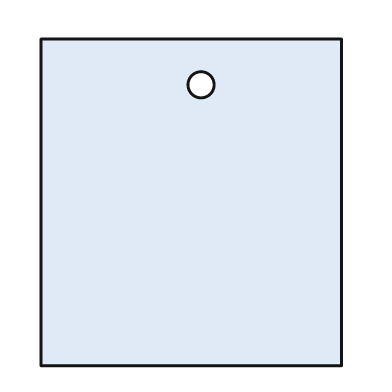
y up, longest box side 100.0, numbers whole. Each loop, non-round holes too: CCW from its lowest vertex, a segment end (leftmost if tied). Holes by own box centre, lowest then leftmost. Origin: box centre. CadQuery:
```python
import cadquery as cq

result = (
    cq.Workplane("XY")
    .moveTo(-46.0, -50.0)
    .lineTo(46.0, -50.0)
    .lineTo(46.0, 50.0)
    .lineTo(-46.0, 50.0)
    .close()
    .moveTo(3.0, 36.0)
    .circle(4.0)
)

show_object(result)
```